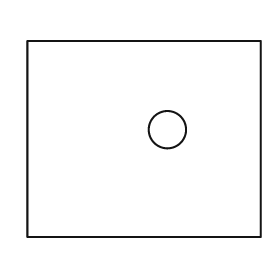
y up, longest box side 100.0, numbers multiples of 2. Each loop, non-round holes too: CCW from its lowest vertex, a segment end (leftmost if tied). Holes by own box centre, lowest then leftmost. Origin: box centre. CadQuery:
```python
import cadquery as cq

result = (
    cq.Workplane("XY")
    .moveTo(-50.0, -42.0)
    .lineTo(50.0, -42.0)
    .lineTo(50.0, 42.0)
    .lineTo(-50.0, 42.0)
    .close()
    .moveTo(10.0, 4.0)
    .circle(8.0)
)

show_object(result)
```